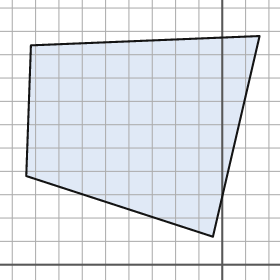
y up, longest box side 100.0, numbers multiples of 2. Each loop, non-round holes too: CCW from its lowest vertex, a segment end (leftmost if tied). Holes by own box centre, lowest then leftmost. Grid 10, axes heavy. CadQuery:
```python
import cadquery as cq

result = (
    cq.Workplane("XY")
    .moveTo(-4.0, 12.0)
    .lineTo(16.0, 98.0)
    .lineTo(-82.0, 94.0)
    .lineTo(-84.0, 38.0)
    .close()
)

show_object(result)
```